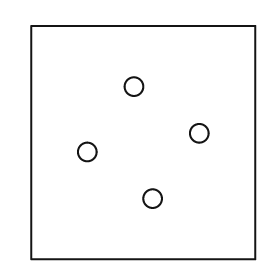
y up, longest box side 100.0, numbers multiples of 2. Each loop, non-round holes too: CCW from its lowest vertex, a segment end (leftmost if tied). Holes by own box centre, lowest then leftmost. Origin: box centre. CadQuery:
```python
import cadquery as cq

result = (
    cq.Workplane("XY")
    .moveTo(-48.0, -50.0)
    .lineTo(48.0, -50.0)
    .lineTo(48.0, 50.0)
    .lineTo(-48.0, 50.0)
    .close()
    .moveTo(4.0, -24.0)
    .circle(4.0)
    .moveTo(-24.0, -4.0)
    .circle(4.0)
    .moveTo(24.0, 4.0)
    .circle(4.0)
    .moveTo(-4.0, 24.0)
    .circle(4.0)
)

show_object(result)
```